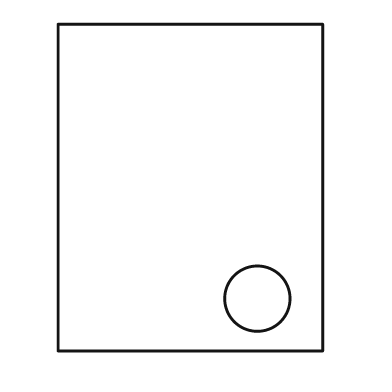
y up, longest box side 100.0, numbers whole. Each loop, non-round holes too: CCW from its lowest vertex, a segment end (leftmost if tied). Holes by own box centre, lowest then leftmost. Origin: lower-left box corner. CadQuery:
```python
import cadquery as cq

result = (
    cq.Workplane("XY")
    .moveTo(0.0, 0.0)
    .lineTo(81.0, 0.0)
    .lineTo(81.0, 100.0)
    .lineTo(0.0, 100.0)
    .close()
    .moveTo(61.0, 16.0)
    .circle(10.0)
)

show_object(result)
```